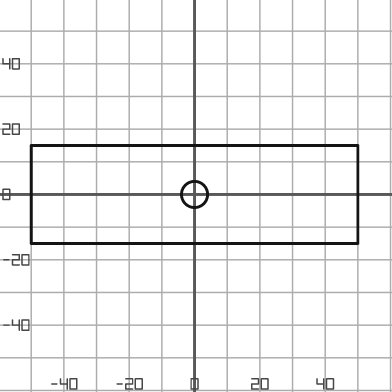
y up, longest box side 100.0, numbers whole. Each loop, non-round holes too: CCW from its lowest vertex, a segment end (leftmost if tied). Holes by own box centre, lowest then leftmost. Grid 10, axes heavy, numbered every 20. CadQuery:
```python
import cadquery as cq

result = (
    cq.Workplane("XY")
    .moveTo(-50.0, -15.0)
    .lineTo(50.0, -15.0)
    .lineTo(50.0, 15.0)
    .lineTo(-50.0, 15.0)
    .close()
    .moveTo(0.0, 0.0)
    .circle(4.0)
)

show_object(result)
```